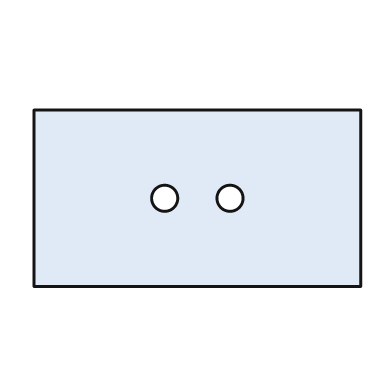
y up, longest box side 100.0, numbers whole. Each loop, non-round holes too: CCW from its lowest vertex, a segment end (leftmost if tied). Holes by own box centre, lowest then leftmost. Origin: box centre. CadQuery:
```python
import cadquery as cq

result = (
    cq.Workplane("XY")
    .moveTo(-50.0, -27.0)
    .lineTo(50.0, -27.0)
    .lineTo(50.0, 27.0)
    .lineTo(-50.0, 27.0)
    .close()
    .moveTo(-10.0, 0.0)
    .circle(4.0)
    .moveTo(10.0, 0.0)
    .circle(4.0)
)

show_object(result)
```